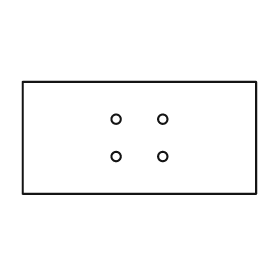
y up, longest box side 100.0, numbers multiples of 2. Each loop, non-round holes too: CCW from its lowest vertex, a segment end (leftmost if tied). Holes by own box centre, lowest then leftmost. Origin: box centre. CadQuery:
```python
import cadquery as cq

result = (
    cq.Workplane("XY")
    .moveTo(-50.0, -24.0)
    .lineTo(50.0, -24.0)
    .lineTo(50.0, 24.0)
    .lineTo(-50.0, 24.0)
    .close()
    .moveTo(-10.0, -8.0)
    .circle(2.0)
    .moveTo(10.0, -8.0)
    .circle(2.0)
    .moveTo(-10.0, 8.0)
    .circle(2.0)
    .moveTo(10.0, 8.0)
    .circle(2.0)
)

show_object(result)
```